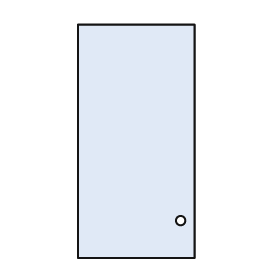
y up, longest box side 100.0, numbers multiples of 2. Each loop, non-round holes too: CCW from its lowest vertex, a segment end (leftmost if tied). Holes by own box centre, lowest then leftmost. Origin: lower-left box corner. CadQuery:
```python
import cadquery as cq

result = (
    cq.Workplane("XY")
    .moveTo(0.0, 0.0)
    .lineTo(50.0, 0.0)
    .lineTo(50.0, 100.0)
    .lineTo(0.0, 100.0)
    .close()
    .moveTo(44.0, 16.0)
    .circle(2.0)
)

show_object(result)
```